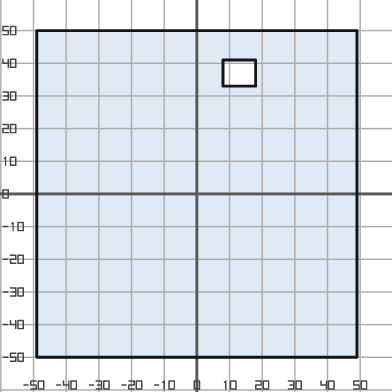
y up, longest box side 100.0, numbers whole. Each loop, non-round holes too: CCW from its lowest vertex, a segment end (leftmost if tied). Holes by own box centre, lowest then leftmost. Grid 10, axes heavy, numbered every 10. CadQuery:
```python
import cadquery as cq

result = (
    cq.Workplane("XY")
    .moveTo(-49.0, -50.0)
    .lineTo(49.0, -50.0)
    .lineTo(49.0, 50.0)
    .lineTo(-49.0, 50.0)
    .close()
    .moveTo(8.0, 33.0)
    .lineTo(18.0, 33.0)
    .lineTo(18.0, 41.0)
    .lineTo(8.0, 41.0)
    .close()
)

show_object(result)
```